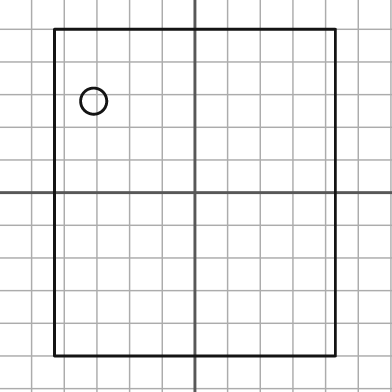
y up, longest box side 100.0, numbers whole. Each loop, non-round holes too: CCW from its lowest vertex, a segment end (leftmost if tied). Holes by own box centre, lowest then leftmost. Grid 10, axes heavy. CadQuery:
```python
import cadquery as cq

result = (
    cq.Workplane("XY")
    .moveTo(-43.0, -50.0)
    .lineTo(43.0, -50.0)
    .lineTo(43.0, 50.0)
    .lineTo(-43.0, 50.0)
    .close()
    .moveTo(-31.0, 28.0)
    .circle(4.0)
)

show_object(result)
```